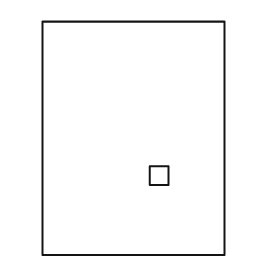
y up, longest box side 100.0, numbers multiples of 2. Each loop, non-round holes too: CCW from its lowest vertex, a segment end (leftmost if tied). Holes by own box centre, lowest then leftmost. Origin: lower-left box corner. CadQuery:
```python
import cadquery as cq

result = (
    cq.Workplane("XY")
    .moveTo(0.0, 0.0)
    .lineTo(78.0, 0.0)
    .lineTo(78.0, 100.0)
    .lineTo(0.0, 100.0)
    .close()
    .moveTo(46.0, 30.0)
    .lineTo(54.0, 30.0)
    .lineTo(54.0, 38.0)
    .lineTo(46.0, 38.0)
    .close()
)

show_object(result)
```